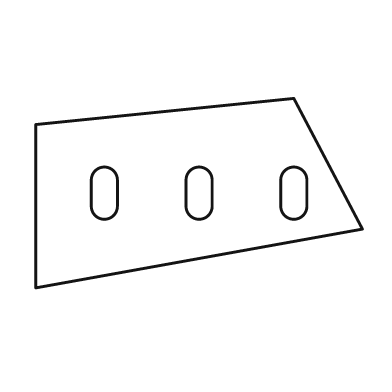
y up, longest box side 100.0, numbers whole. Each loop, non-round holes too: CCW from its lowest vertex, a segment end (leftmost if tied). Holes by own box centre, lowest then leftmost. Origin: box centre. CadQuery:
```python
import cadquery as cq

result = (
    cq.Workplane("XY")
    .moveTo(-50.0, -29.0)
    .lineTo(50.0, -11.0)
    .lineTo(29.0, 29.0)
    .lineTo(-50.0, 21.0)
    .close()
    .moveTo(-33.0, -4.0)
    .threePointArc((-29.0, -8.0), (-25.0, -4.0))
    .lineTo(-25.0, 4.0)
    .threePointArc((-29.0, 8.0), (-33.0, 4.0))
    .close()
    .moveTo(-4.0, -4.0)
    .threePointArc((0.0, -8.0), (4.0, -4.0))
    .lineTo(4.0, 4.0)
    .threePointArc((0.0, 8.0), (-4.0, 4.0))
    .close()
    .moveTo(25.0, -4.0)
    .threePointArc((29.0, -8.0), (33.0, -4.0))
    .lineTo(33.0, 4.0)
    .threePointArc((29.0, 8.0), (25.0, 4.0))
    .close()
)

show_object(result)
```